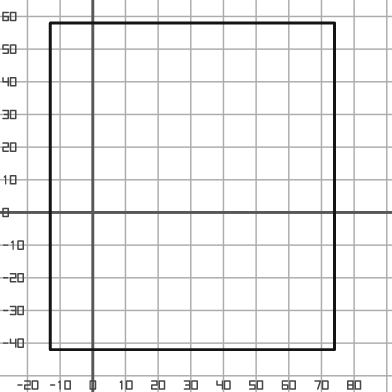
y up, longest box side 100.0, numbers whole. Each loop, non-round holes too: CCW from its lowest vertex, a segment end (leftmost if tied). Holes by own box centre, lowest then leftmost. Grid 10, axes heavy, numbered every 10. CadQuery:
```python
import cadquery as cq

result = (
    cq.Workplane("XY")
    .moveTo(-13.0, -42.0)
    .lineTo(74.0, -42.0)
    .lineTo(74.0, 58.0)
    .lineTo(-13.0, 58.0)
    .close()
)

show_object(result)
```